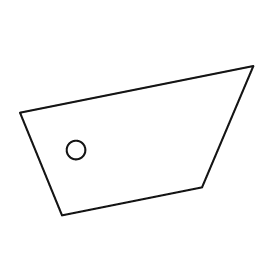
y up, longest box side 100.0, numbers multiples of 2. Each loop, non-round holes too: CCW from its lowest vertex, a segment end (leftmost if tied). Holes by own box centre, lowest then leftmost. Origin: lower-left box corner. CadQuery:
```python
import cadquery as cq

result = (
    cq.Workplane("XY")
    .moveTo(18.0, 0.0)
    .lineTo(78.0, 12.0)
    .lineTo(100.0, 64.0)
    .lineTo(0.0, 44.0)
    .close()
    .moveTo(24.0, 28.0)
    .circle(4.0)
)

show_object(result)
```